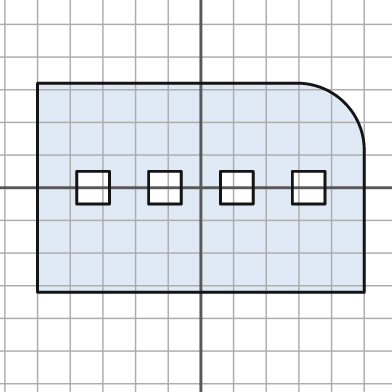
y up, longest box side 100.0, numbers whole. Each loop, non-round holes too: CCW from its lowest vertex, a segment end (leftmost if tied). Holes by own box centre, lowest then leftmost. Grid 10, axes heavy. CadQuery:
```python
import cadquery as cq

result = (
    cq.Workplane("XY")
    .moveTo(-50.0, -32.0)
    .lineTo(50.0, -32.0)
    .lineTo(50.0, 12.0)
    .threePointArc((44.0, 26.0), (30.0, 32.0))
    .lineTo(-50.0, 32.0)
    .close()
    .moveTo(-38.0, -5.0)
    .lineTo(-28.0, -5.0)
    .lineTo(-28.0, 5.0)
    .lineTo(-38.0, 5.0)
    .close()
    .moveTo(-16.0, -5.0)
    .lineTo(-6.0, -5.0)
    .lineTo(-6.0, 5.0)
    .lineTo(-16.0, 5.0)
    .close()
    .moveTo(6.0, -5.0)
    .lineTo(16.0, -5.0)
    .lineTo(16.0, 5.0)
    .lineTo(6.0, 5.0)
    .close()
    .moveTo(28.0, -5.0)
    .lineTo(38.0, -5.0)
    .lineTo(38.0, 5.0)
    .lineTo(28.0, 5.0)
    .close()
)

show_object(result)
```